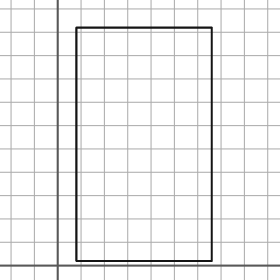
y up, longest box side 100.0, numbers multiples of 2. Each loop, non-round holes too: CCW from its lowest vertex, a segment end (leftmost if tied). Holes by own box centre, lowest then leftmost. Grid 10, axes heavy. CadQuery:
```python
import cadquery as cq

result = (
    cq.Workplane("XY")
    .moveTo(8.0, 2.0)
    .lineTo(66.0, 2.0)
    .lineTo(66.0, 102.0)
    .lineTo(8.0, 102.0)
    .close()
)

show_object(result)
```